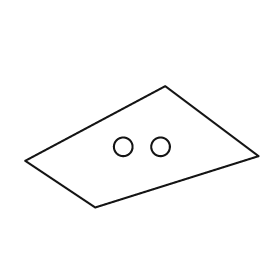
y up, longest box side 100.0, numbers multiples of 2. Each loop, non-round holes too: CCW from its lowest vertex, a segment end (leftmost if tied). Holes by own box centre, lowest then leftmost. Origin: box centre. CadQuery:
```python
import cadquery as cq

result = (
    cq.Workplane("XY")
    .moveTo(-20.0, -26.0)
    .lineTo(50.0, -4.0)
    .lineTo(10.0, 26.0)
    .lineTo(-50.0, -6.0)
    .close()
    .moveTo(-8.0, 0.0)
    .circle(4.0)
    .moveTo(8.0, 0.0)
    .circle(4.0)
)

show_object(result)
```